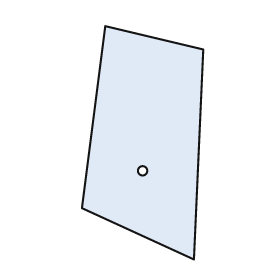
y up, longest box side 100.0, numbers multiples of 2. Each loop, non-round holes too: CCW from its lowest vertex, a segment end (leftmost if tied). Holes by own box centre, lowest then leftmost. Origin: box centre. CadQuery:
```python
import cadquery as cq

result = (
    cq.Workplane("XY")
    .moveTo(22.0, -50.0)
    .lineTo(26.0, 40.0)
    .lineTo(-16.0, 50.0)
    .lineTo(-26.0, -28.0)
    .close()
    .moveTo(0.0, -12.0)
    .circle(2.0)
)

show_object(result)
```